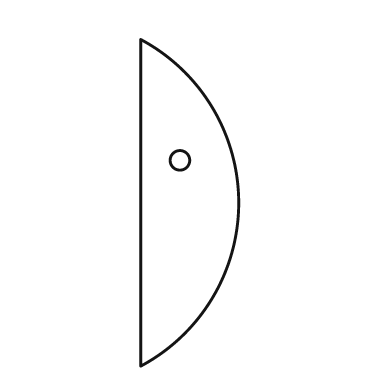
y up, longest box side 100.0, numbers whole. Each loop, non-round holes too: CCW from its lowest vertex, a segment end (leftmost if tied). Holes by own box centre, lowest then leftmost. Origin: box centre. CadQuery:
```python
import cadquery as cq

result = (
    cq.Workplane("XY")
    .moveTo(-15.0, -50.0)
    .threePointArc((15.0, 0.0), (-15.0, 50.0))
    .close()
    .moveTo(-3.0, 13.0)
    .circle(3.0)
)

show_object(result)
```